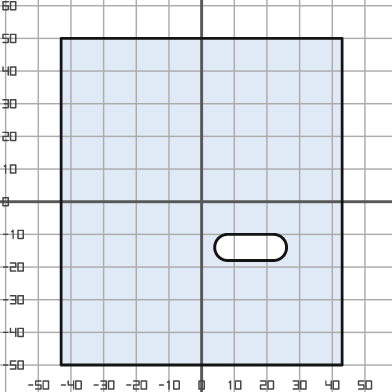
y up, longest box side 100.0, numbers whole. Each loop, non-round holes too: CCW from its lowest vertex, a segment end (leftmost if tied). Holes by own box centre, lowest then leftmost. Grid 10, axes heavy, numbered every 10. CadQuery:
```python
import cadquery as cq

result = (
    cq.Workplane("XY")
    .moveTo(-43.0, -50.0)
    .lineTo(43.0, -50.0)
    .lineTo(43.0, 50.0)
    .lineTo(-43.0, 50.0)
    .close()
    .moveTo(8.0, -18.0)
    .lineTo(22.0, -18.0)
    .threePointArc((26.0, -14.0), (22.0, -10.0))
    .lineTo(8.0, -10.0)
    .threePointArc((4.0, -14.0), (8.0, -18.0))
    .close()
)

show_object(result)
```